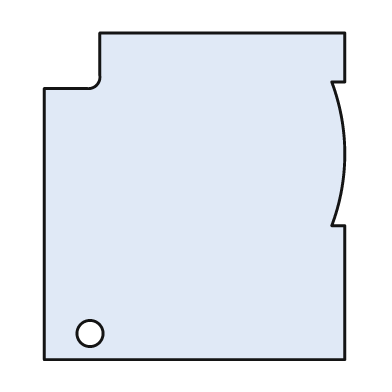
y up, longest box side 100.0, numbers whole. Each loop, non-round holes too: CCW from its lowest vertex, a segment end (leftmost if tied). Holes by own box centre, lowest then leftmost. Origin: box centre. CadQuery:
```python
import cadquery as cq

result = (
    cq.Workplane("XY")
    .moveTo(-46.0, -50.0)
    .lineTo(46.0, -50.0)
    .lineTo(46.0, -9.0)
    .lineTo(42.0, -9.0)
    .threePointArc((46.0, 13.0), (42.0, 35.0))
    .lineTo(46.0, 35.0)
    .lineTo(46.0, 50.0)
    .lineTo(-29.0, 50.0)
    .lineTo(-29.0, 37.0)
    .threePointArc((-30.0, 34.0), (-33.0, 33.0))
    .lineTo(-46.0, 33.0)
    .close()
    .moveTo(-32.0, -42.0)
    .circle(4.0)
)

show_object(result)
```